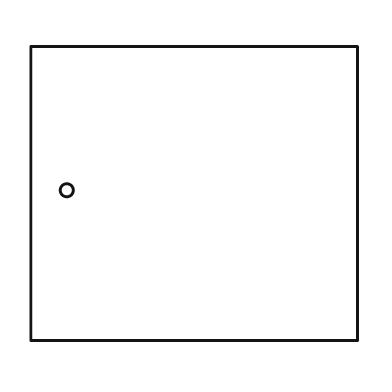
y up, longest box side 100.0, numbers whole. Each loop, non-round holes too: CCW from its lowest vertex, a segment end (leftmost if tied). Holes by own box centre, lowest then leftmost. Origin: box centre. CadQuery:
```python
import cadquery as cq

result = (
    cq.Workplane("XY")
    .moveTo(-50.0, -45.0)
    .lineTo(50.0, -45.0)
    .lineTo(50.0, 45.0)
    .lineTo(-50.0, 45.0)
    .close()
    .moveTo(-39.0, 1.0)
    .circle(2.0)
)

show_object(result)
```